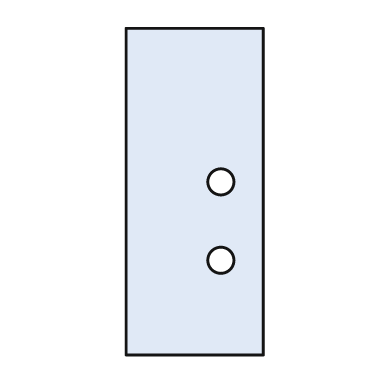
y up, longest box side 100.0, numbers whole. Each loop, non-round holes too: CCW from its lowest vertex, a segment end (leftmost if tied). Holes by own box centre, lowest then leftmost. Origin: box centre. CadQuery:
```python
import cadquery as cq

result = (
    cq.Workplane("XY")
    .moveTo(-21.0, -50.0)
    .lineTo(21.0, -50.0)
    .lineTo(21.0, 50.0)
    .lineTo(-21.0, 50.0)
    .close()
    .moveTo(8.0, -21.0)
    .circle(4.0)
    .moveTo(8.0, 3.0)
    .circle(4.0)
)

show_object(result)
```